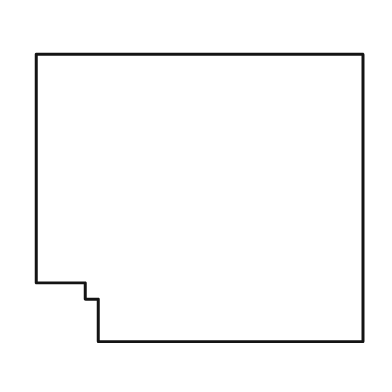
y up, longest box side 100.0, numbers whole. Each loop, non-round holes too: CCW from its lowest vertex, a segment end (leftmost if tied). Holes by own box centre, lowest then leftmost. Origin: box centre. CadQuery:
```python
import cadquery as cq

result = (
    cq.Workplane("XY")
    .moveTo(-31.0, -44.0)
    .lineTo(50.0, -44.0)
    .lineTo(50.0, 44.0)
    .lineTo(-50.0, 44.0)
    .lineTo(-50.0, -26.0)
    .lineTo(-35.0, -26.0)
    .lineTo(-35.0, -31.0)
    .lineTo(-31.0, -31.0)
    .close()
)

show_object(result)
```